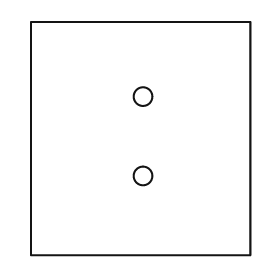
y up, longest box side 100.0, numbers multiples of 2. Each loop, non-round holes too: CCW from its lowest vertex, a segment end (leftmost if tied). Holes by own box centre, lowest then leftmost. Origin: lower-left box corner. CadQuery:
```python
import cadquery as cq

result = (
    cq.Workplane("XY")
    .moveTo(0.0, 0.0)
    .lineTo(94.0, 0.0)
    .lineTo(94.0, 100.0)
    .lineTo(0.0, 100.0)
    .close()
    .moveTo(48.0, 34.0)
    .circle(4.0)
    .moveTo(48.0, 68.0)
    .circle(4.0)
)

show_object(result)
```